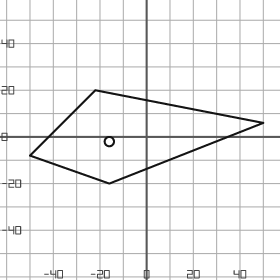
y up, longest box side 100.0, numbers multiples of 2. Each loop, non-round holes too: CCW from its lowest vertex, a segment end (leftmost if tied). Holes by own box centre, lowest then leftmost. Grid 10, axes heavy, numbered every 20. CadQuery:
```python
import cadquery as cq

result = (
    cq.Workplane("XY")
    .moveTo(-16.0, -20.0)
    .lineTo(50.0, 6.0)
    .lineTo(-22.0, 20.0)
    .lineTo(-50.0, -8.0)
    .close()
    .moveTo(-16.0, -2.0)
    .circle(2.0)
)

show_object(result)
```